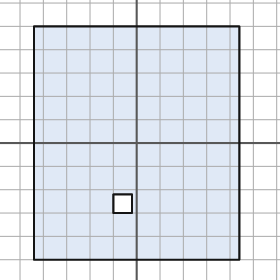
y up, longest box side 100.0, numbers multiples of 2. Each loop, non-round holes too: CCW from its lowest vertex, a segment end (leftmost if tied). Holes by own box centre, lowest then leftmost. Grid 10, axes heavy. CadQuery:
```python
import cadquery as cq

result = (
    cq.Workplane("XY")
    .moveTo(-44.0, -50.0)
    .lineTo(44.0, -50.0)
    .lineTo(44.0, 50.0)
    .lineTo(-44.0, 50.0)
    .close()
    .moveTo(-10.0, -30.0)
    .lineTo(-2.0, -30.0)
    .lineTo(-2.0, -22.0)
    .lineTo(-10.0, -22.0)
    .close()
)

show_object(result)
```